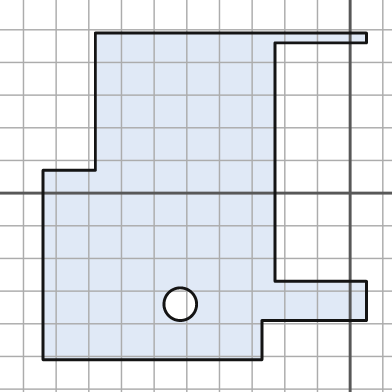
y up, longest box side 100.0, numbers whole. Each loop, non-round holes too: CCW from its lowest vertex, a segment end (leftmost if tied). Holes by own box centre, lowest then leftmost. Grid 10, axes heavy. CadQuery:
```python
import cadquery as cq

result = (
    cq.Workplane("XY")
    .moveTo(-94.0, -51.0)
    .lineTo(-27.0, -51.0)
    .lineTo(-27.0, -39.0)
    .lineTo(5.0, -39.0)
    .lineTo(5.0, -27.0)
    .lineTo(-23.0, -27.0)
    .lineTo(-23.0, 46.0)
    .lineTo(5.0, 46.0)
    .lineTo(5.0, 49.0)
    .lineTo(-78.0, 49.0)
    .lineTo(-78.0, 7.0)
    .lineTo(-94.0, 7.0)
    .close()
    .moveTo(-52.0, -34.0)
    .circle(5.0)
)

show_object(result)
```